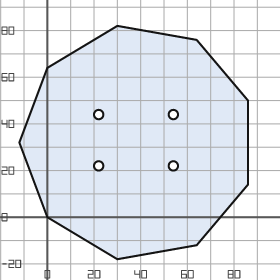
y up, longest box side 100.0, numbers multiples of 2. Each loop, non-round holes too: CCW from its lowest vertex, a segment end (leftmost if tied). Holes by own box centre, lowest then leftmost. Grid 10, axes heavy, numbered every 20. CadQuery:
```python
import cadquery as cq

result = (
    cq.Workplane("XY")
    .moveTo(30.0, -18.0)
    .lineTo(64.0, -12.0)
    .lineTo(86.0, 14.0)
    .lineTo(86.0, 50.0)
    .lineTo(64.0, 76.0)
    .lineTo(30.0, 82.0)
    .lineTo(0.0, 64.0)
    .lineTo(-12.0, 32.0)
    .lineTo(0.0, 0.0)
    .close()
    .moveTo(22.0, 22.0)
    .circle(2.0)
    .moveTo(54.0, 22.0)
    .circle(2.0)
    .moveTo(22.0, 44.0)
    .circle(2.0)
    .moveTo(54.0, 44.0)
    .circle(2.0)
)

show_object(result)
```